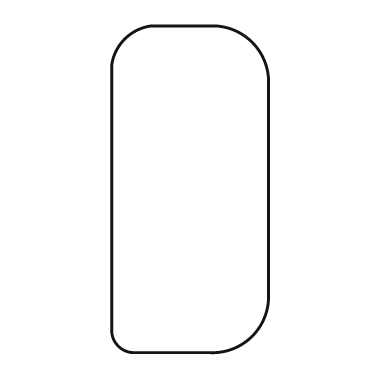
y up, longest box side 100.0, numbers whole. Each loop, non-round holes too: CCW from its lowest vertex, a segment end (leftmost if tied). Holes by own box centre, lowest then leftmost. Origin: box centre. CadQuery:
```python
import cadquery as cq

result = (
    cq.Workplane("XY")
    .moveTo(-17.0, -50.0)
    .lineTo(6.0, -50.0)
    .threePointArc((19.0, -45.0), (24.0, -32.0))
    .lineTo(24.0, 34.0)
    .threePointArc((19.0, 45.0), (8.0, 50.0))
    .lineTo(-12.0, 50.0)
    .threePointArc((-20.0, 46.0), (-24.0, 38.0))
    .lineTo(-24.0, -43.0)
    .threePointArc((-22.0, -48.0), (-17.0, -50.0))
    .close()
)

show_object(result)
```